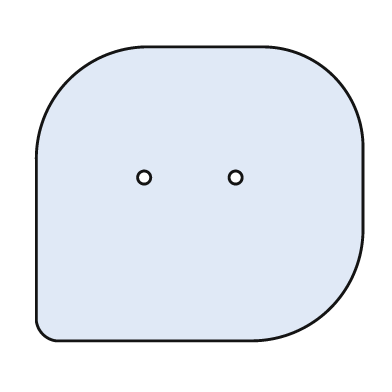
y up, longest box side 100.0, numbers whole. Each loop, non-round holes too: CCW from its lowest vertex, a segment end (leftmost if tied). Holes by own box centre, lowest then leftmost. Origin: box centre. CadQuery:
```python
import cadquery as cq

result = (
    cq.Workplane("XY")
    .moveTo(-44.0, -45.0)
    .lineTo(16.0, -45.0)
    .threePointArc((40.0, -35.0), (50.0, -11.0))
    .lineTo(50.0, 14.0)
    .threePointArc((41.0, 36.0), (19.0, 45.0))
    .lineTo(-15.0, 45.0)
    .threePointArc((-40.0, 35.0), (-50.0, 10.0))
    .lineTo(-50.0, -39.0)
    .threePointArc((-48.0, -43.0), (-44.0, -45.0))
    .close()
    .moveTo(-17.0, 5.0)
    .circle(2.0)
    .moveTo(11.0, 5.0)
    .circle(2.0)
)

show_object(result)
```